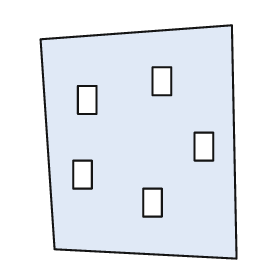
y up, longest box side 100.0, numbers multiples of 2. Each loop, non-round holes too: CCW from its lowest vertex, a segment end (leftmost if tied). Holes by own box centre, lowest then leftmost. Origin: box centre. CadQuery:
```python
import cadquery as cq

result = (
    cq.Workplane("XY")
    .moveTo(42.0, -50.0)
    .lineTo(40.0, 50.0)
    .lineTo(-42.0, 44.0)
    .lineTo(-36.0, -46.0)
    .close()
    .moveTo(2.0, -32.0)
    .lineTo(10.0, -32.0)
    .lineTo(10.0, -20.0)
    .lineTo(2.0, -20.0)
    .close()
    .moveTo(-28.0, -20.0)
    .lineTo(-20.0, -20.0)
    .lineTo(-20.0, -8.0)
    .lineTo(-28.0, -8.0)
    .close()
    .moveTo(24.0, -8.0)
    .lineTo(32.0, -8.0)
    .lineTo(32.0, 4.0)
    .lineTo(24.0, 4.0)
    .close()
    .moveTo(-26.0, 12.0)
    .lineTo(-18.0, 12.0)
    .lineTo(-18.0, 24.0)
    .lineTo(-26.0, 24.0)
    .close()
    .moveTo(6.0, 20.0)
    .lineTo(14.0, 20.0)
    .lineTo(14.0, 32.0)
    .lineTo(6.0, 32.0)
    .close()
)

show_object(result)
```